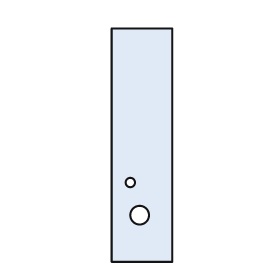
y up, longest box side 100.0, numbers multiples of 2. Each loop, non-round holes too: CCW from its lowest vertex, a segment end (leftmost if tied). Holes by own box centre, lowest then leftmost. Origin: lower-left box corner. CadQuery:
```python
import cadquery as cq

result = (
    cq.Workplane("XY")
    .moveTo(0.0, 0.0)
    .lineTo(26.0, 0.0)
    .lineTo(26.0, 100.0)
    .lineTo(0.0, 100.0)
    .close()
    .moveTo(12.0, 20.0)
    .circle(4.0)
    .moveTo(8.0, 34.0)
    .circle(2.0)
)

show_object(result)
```